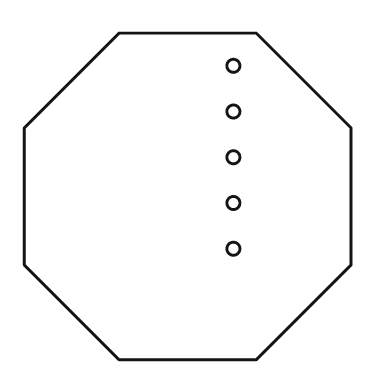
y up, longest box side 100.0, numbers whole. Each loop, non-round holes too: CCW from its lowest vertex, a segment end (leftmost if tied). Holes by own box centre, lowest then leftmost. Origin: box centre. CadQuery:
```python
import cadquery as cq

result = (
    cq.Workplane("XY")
    .moveTo(-21.0, -50.0)
    .lineTo(21.0, -50.0)
    .lineTo(50.0, -21.0)
    .lineTo(50.0, 21.0)
    .lineTo(21.0, 50.0)
    .lineTo(-21.0, 50.0)
    .lineTo(-50.0, 21.0)
    .lineTo(-50.0, -21.0)
    .close()
    .moveTo(14.0, -16.0)
    .circle(2.0)
    .moveTo(14.0, -2.0)
    .circle(2.0)
    .moveTo(14.0, 12.0)
    .circle(2.0)
    .moveTo(14.0, 26.0)
    .circle(2.0)
    .moveTo(14.0, 40.0)
    .circle(2.0)
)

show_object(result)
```